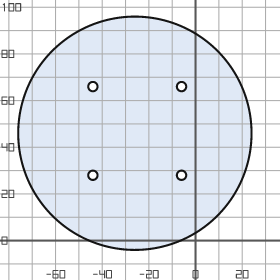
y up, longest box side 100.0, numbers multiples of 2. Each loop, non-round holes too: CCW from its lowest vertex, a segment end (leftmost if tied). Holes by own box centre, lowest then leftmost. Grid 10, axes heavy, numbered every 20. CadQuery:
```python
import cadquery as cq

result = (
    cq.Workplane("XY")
    .moveTo(-26.0, 46.0)
    .circle(50.0)
    .moveTo(-44.0, 28.0)
    .circle(2.0)
    .moveTo(-6.0, 28.0)
    .circle(2.0)
    .moveTo(-44.0, 66.0)
    .circle(2.0)
    .moveTo(-6.0, 66.0)
    .circle(2.0)
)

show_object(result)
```